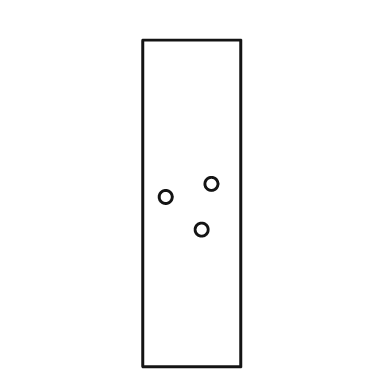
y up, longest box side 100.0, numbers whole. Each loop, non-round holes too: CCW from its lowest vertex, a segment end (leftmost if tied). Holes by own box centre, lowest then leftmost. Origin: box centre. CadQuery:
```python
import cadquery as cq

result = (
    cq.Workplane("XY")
    .moveTo(-15.0, -50.0)
    .lineTo(15.0, -50.0)
    .lineTo(15.0, 50.0)
    .lineTo(-15.0, 50.0)
    .close()
    .moveTo(3.0, -8.0)
    .circle(2.0)
    .moveTo(-8.0, 2.0)
    .circle(2.0)
    .moveTo(6.0, 6.0)
    .circle(2.0)
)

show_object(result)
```